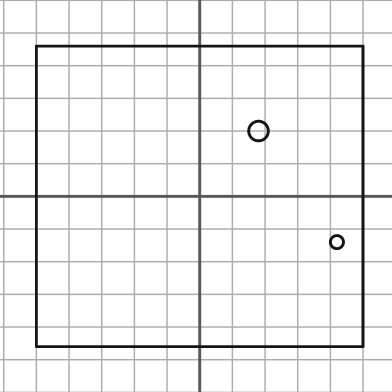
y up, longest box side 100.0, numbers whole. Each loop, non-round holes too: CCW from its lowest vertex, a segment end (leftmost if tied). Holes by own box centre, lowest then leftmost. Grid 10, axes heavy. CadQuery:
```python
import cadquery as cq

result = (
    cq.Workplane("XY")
    .moveTo(-50.0, -46.0)
    .lineTo(50.0, -46.0)
    .lineTo(50.0, 46.0)
    .lineTo(-50.0, 46.0)
    .close()
    .moveTo(42.0, -14.0)
    .circle(2.0)
    .moveTo(18.0, 20.0)
    .circle(3.0)
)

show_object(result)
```